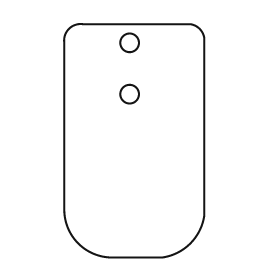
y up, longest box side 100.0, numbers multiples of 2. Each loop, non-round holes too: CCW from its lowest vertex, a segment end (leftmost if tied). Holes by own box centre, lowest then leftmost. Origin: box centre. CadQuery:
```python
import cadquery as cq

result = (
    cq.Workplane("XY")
    .moveTo(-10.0, -50.0)
    .lineTo(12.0, -50.0)
    .threePointArc((24.0, -44.0), (30.0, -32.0))
    .lineTo(30.0, 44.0)
    .threePointArc((28.0, 48.0), (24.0, 50.0))
    .lineTo(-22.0, 50.0)
    .threePointArc((-28.0, 48.0), (-30.0, 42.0))
    .lineTo(-30.0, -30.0)
    .threePointArc((-24.0, -44.0), (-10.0, -50.0))
    .close()
    .moveTo(-2.0, 20.0)
    .circle(4.0)
    .moveTo(-2.0, 42.0)
    .circle(4.0)
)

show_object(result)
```